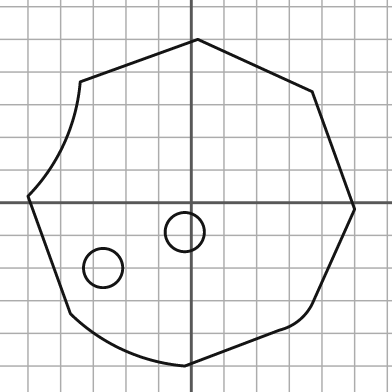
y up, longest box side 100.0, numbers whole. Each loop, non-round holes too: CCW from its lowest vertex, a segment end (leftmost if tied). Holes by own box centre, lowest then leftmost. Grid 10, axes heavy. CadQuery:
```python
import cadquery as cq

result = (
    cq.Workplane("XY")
    .moveTo(-2.0, -50.0)
    .lineTo(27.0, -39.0)
    .threePointArc((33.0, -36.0), (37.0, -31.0))
    .lineTo(50.0, -2.0)
    .lineTo(37.0, 34.0)
    .lineTo(2.0, 50.0)
    .lineTo(-34.0, 37.0)
    .threePointArc((-39.0, 18.0), (-50.0, 2.0))
    .lineTo(-37.0, -34.0)
    .threePointArc((-21.0, -45.0), (-2.0, -50.0))
    .close()
    .moveTo(-27.0, -20.0)
    .circle(6.0)
    .moveTo(-2.0, -9.0)
    .circle(6.0)
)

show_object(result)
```